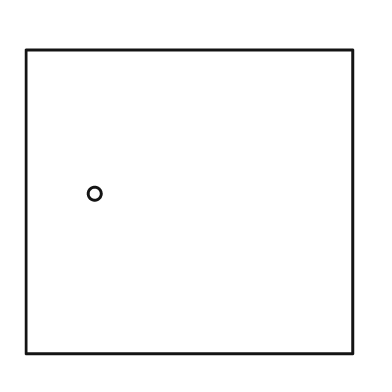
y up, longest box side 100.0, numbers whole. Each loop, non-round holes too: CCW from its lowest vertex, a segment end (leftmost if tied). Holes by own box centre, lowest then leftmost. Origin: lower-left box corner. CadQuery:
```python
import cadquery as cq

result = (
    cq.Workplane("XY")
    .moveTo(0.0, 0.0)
    .lineTo(100.0, 0.0)
    .lineTo(100.0, 93.0)
    .lineTo(0.0, 93.0)
    .close()
    .moveTo(21.0, 49.0)
    .circle(2.0)
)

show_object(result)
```